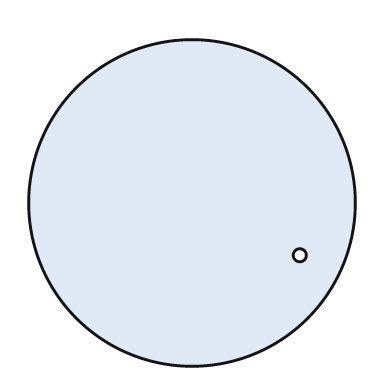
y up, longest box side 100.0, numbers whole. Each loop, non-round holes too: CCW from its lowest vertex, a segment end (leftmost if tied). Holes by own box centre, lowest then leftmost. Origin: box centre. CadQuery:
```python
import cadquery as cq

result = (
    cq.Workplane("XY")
    .moveTo(0.0, 0.0)
    .circle(50.0)
    .moveTo(33.0, -16.0)
    .circle(2.0)
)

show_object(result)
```